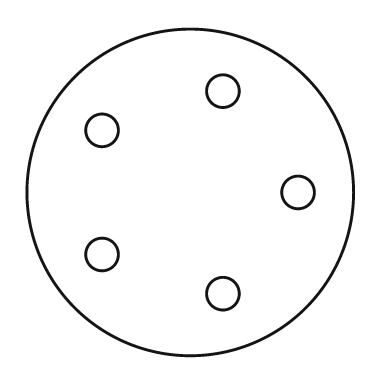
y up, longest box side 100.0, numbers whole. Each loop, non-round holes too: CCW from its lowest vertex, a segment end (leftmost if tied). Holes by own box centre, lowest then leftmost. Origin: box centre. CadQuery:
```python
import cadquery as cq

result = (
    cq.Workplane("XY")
    .moveTo(0.0, 0.0)
    .circle(50.0)
    .moveTo(10.0, -31.0)
    .circle(5.0)
    .moveTo(-27.0, -19.0)
    .circle(5.0)
    .moveTo(33.0, 0.0)
    .circle(5.0)
    .moveTo(-27.0, 19.0)
    .circle(5.0)
    .moveTo(10.0, 31.0)
    .circle(5.0)
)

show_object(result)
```